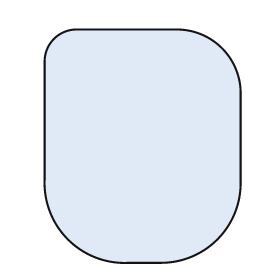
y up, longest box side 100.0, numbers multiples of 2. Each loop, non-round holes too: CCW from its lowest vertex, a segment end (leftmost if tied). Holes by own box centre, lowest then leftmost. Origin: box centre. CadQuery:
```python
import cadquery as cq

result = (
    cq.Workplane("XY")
    .moveTo(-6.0, -50.0)
    .lineTo(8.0, -50.0)
    .threePointArc((32.0, -40.0), (42.0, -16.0))
    .lineTo(42.0, 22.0)
    .threePointArc((34.0, 42.0), (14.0, 50.0))
    .lineTo(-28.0, 50.0)
    .threePointArc((-38.0, 46.0), (-42.0, 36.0))
    .lineTo(-42.0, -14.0)
    .threePointArc((-32.0, -40.0), (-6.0, -50.0))
    .close()
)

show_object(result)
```